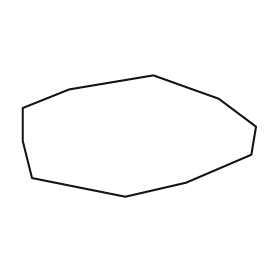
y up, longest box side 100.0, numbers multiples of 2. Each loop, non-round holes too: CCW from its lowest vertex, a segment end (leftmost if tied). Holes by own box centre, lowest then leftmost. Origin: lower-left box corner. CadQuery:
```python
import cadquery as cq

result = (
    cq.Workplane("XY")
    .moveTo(44.0, 0.0)
    .lineTo(70.0, 6.0)
    .lineTo(98.0, 18.0)
    .lineTo(100.0, 30.0)
    .lineTo(84.0, 42.0)
    .lineTo(56.0, 52.0)
    .lineTo(20.0, 46.0)
    .lineTo(0.0, 38.0)
    .lineTo(0.0, 24.0)
    .lineTo(4.0, 8.0)
    .close()
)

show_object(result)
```